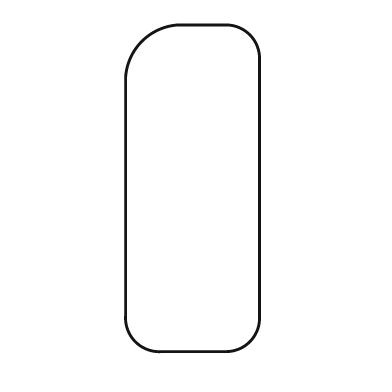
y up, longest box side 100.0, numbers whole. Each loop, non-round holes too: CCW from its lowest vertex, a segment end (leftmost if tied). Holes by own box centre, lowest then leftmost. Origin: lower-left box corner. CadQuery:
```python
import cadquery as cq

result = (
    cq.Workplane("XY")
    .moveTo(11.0, 0.0)
    .lineTo(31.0, 0.0)
    .threePointArc((38.0, 3.0), (41.0, 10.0))
    .lineTo(41.0, 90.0)
    .threePointArc((38.0, 97.0), (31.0, 100.0))
    .lineTo(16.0, 100.0)
    .threePointArc((5.0, 95.0), (0.0, 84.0))
    .lineTo(0.0, 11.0)
    .threePointArc((3.0, 3.0), (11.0, 0.0))
    .close()
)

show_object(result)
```